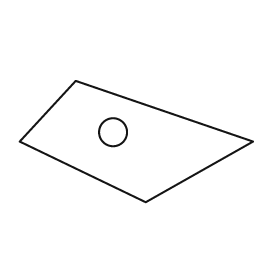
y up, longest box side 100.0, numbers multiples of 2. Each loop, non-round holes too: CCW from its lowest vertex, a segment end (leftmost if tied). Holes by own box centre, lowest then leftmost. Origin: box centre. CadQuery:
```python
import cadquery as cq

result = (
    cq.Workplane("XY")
    .moveTo(4.0, -26.0)
    .lineTo(50.0, 0.0)
    .lineTo(-26.0, 26.0)
    .lineTo(-50.0, 0.0)
    .close()
    .moveTo(-10.0, 4.0)
    .circle(6.0)
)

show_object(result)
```